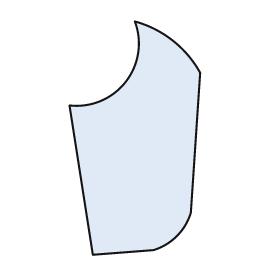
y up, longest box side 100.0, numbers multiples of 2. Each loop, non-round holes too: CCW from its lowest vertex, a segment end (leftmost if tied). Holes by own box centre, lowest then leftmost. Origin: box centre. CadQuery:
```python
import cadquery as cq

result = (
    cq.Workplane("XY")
    .moveTo(-18.0, -50.0)
    .lineTo(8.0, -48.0)
    .threePointArc((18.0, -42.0), (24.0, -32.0))
    .lineTo(28.0, 28.0)
    .threePointArc((16.0, 42.0), (0.0, 50.0))
    .threePointArc((-4.0, 24.0), (-28.0, 14.0))
    .close()
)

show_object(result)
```